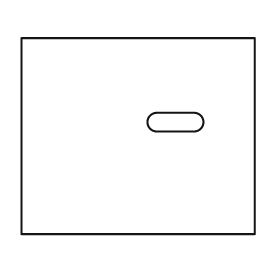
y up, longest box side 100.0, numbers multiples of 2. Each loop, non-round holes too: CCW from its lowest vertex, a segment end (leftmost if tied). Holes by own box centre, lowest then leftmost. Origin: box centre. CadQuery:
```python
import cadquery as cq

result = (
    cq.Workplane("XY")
    .moveTo(-50.0, -42.0)
    .lineTo(50.0, -42.0)
    .lineTo(50.0, 42.0)
    .lineTo(-50.0, 42.0)
    .close()
    .moveTo(8.0, 2.0)
    .lineTo(24.0, 2.0)
    .threePointArc((28.0, 6.0), (24.0, 10.0))
    .lineTo(8.0, 10.0)
    .threePointArc((4.0, 6.0), (8.0, 2.0))
    .close()
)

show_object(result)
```